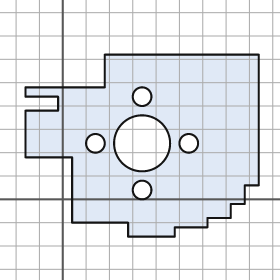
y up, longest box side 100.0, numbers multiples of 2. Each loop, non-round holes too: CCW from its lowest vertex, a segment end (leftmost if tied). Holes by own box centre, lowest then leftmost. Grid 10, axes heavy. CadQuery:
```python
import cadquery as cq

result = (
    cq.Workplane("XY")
    .moveTo(28.0, -16.0)
    .lineTo(48.0, -16.0)
    .lineTo(48.0, -12.0)
    .lineTo(62.0, -12.0)
    .lineTo(62.0, -8.0)
    .lineTo(72.0, -8.0)
    .lineTo(72.0, -2.0)
    .lineTo(78.0, -2.0)
    .lineTo(78.0, 6.0)
    .lineTo(84.0, 6.0)
    .lineTo(84.0, 62.0)
    .lineTo(18.0, 62.0)
    .lineTo(18.0, 48.0)
    .lineTo(-16.0, 48.0)
    .lineTo(-16.0, 44.0)
    .lineTo(-2.0, 44.0)
    .lineTo(-2.0, 38.0)
    .lineTo(-16.0, 38.0)
    .lineTo(-16.0, 18.0)
    .lineTo(4.0, 18.0)
    .lineTo(4.0, -10.0)
    .lineTo(28.0, -10.0)
    .close()
    .moveTo(34.0, 4.0)
    .circle(4.0)
    .moveTo(14.0, 24.0)
    .circle(4.0)
    .moveTo(34.0, 24.0)
    .circle(12.0)
    .moveTo(54.0, 24.0)
    .circle(4.0)
    .moveTo(34.0, 44.0)
    .circle(4.0)
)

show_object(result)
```